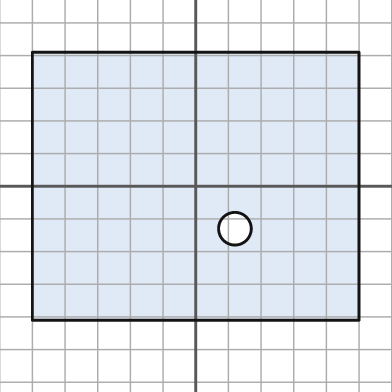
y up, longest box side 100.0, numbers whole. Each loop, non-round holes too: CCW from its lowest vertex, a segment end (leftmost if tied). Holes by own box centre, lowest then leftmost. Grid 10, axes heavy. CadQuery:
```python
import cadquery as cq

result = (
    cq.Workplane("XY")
    .moveTo(-50.0, -41.0)
    .lineTo(50.0, -41.0)
    .lineTo(50.0, 41.0)
    .lineTo(-50.0, 41.0)
    .close()
    .moveTo(12.0, -13.0)
    .circle(5.0)
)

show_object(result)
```